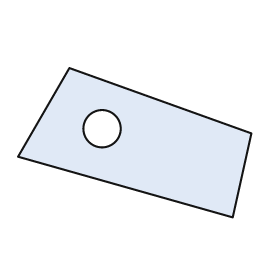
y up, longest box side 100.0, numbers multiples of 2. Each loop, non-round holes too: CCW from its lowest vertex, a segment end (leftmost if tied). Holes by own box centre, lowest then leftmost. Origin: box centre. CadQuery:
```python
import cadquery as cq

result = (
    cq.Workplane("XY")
    .moveTo(42.0, -32.0)
    .lineTo(50.0, 4.0)
    .lineTo(-28.0, 32.0)
    .lineTo(-50.0, -6.0)
    .close()
    .moveTo(-14.0, 6.0)
    .circle(8.0)
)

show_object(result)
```